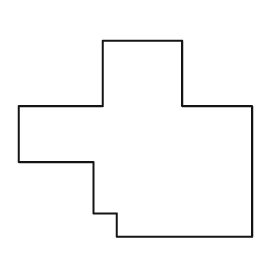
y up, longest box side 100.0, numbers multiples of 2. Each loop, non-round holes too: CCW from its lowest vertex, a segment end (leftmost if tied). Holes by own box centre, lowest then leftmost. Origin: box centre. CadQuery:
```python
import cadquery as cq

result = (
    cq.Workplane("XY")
    .moveTo(-8.0, -42.0)
    .lineTo(50.0, -42.0)
    .lineTo(50.0, 14.0)
    .lineTo(20.0, 14.0)
    .lineTo(20.0, 42.0)
    .lineTo(-14.0, 42.0)
    .lineTo(-14.0, 14.0)
    .lineTo(-50.0, 14.0)
    .lineTo(-50.0, -10.0)
    .lineTo(-18.0, -10.0)
    .lineTo(-18.0, -32.0)
    .lineTo(-8.0, -32.0)
    .close()
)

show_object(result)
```